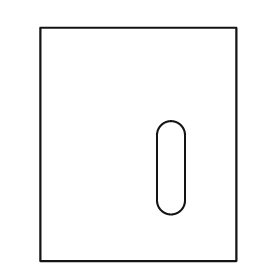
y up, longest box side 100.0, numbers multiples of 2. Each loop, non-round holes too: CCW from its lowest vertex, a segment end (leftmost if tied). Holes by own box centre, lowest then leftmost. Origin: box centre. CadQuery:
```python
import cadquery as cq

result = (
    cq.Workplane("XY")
    .moveTo(-42.0, -50.0)
    .lineTo(42.0, -50.0)
    .lineTo(42.0, 50.0)
    .lineTo(-42.0, 50.0)
    .close()
    .moveTo(8.0, -24.0)
    .threePointArc((14.0, -30.0), (20.0, -24.0))
    .lineTo(20.0, 4.0)
    .threePointArc((14.0, 10.0), (8.0, 4.0))
    .close()
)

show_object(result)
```